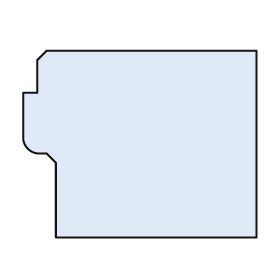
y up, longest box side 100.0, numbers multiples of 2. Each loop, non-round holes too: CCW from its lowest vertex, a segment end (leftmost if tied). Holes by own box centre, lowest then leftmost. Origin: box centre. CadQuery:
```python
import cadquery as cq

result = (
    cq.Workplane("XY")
    .moveTo(-36.0, -40.0)
    .lineTo(50.0, -40.0)
    .lineTo(50.0, 40.0)
    .lineTo(-40.0, 40.0)
    .lineTo(-44.0, 36.0)
    .lineTo(-44.0, 22.0)
    .lineTo(-50.0, 22.0)
    .lineTo(-50.0, 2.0)
    .threePointArc((-48.0, -2.0), (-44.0, -4.0))
    .lineTo(-40.0, -4.0)
    .lineTo(-36.0, -8.0)
    .close()
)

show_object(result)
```